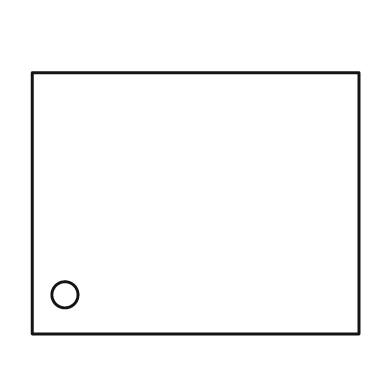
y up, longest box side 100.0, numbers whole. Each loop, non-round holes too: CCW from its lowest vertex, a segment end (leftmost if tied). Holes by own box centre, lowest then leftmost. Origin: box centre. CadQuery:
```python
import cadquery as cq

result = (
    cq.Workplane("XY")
    .moveTo(-50.0, -40.0)
    .lineTo(50.0, -40.0)
    .lineTo(50.0, 40.0)
    .lineTo(-50.0, 40.0)
    .close()
    .moveTo(-40.0, -28.0)
    .circle(4.0)
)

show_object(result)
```